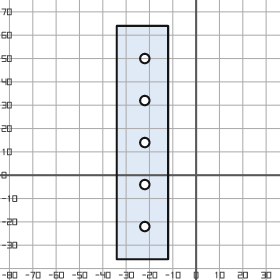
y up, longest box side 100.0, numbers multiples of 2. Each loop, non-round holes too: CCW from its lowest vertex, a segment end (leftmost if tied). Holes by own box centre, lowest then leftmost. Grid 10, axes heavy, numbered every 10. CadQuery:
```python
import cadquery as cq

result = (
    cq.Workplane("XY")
    .moveTo(-34.0, -36.0)
    .lineTo(-12.0, -36.0)
    .lineTo(-12.0, 64.0)
    .lineTo(-34.0, 64.0)
    .close()
    .moveTo(-22.0, -22.0)
    .circle(2.0)
    .moveTo(-22.0, -4.0)
    .circle(2.0)
    .moveTo(-22.0, 14.0)
    .circle(2.0)
    .moveTo(-22.0, 32.0)
    .circle(2.0)
    .moveTo(-22.0, 50.0)
    .circle(2.0)
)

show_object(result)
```